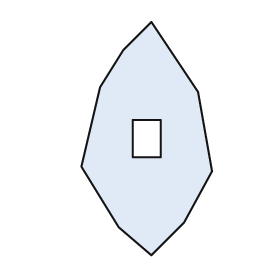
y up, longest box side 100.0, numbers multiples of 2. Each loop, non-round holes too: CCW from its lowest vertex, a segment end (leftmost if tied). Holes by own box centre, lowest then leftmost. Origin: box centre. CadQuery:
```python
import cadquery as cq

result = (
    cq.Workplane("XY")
    .moveTo(2.0, -50.0)
    .lineTo(16.0, -36.0)
    .lineTo(28.0, -14.0)
    .lineTo(22.0, 20.0)
    .lineTo(2.0, 50.0)
    .lineTo(-10.0, 38.0)
    .lineTo(-20.0, 22.0)
    .lineTo(-28.0, -12.0)
    .lineTo(-12.0, -38.0)
    .close()
    .moveTo(-6.0, -8.0)
    .lineTo(6.0, -8.0)
    .lineTo(6.0, 8.0)
    .lineTo(-6.0, 8.0)
    .close()
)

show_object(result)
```